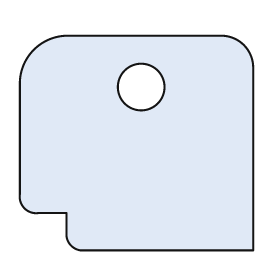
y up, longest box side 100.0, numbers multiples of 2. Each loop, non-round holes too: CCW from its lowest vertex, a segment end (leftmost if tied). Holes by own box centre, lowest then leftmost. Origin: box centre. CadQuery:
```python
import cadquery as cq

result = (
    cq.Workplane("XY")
    .moveTo(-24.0, -46.0)
    .lineTo(50.0, -46.0)
    .lineTo(50.0, 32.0)
    .threePointArc((46.0, 42.0), (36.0, 46.0))
    .lineTo(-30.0, 46.0)
    .threePointArc((-44.0, 40.0), (-50.0, 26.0))
    .lineTo(-50.0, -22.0)
    .threePointArc((-48.0, -28.0), (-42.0, -30.0))
    .lineTo(-30.0, -30.0)
    .lineTo(-30.0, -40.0)
    .threePointArc((-28.0, -44.0), (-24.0, -46.0))
    .close()
    .moveTo(2.0, 24.0)
    .circle(10.0)
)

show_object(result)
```